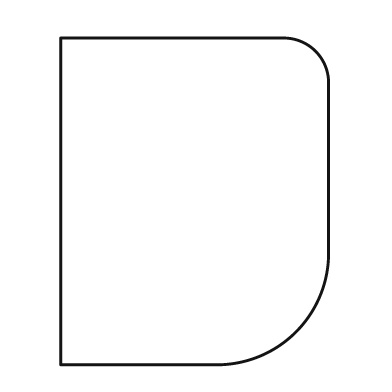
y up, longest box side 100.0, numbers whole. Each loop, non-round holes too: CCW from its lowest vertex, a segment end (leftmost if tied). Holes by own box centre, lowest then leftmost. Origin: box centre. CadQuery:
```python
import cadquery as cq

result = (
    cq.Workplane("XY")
    .moveTo(-41.0, -50.0)
    .lineTo(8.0, -50.0)
    .threePointArc((31.0, -40.0), (41.0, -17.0))
    .lineTo(41.0, 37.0)
    .threePointArc((37.0, 46.0), (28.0, 50.0))
    .lineTo(-41.0, 50.0)
    .close()
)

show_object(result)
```